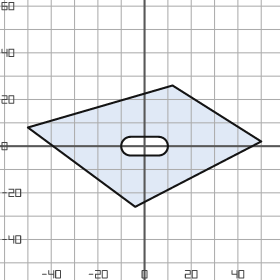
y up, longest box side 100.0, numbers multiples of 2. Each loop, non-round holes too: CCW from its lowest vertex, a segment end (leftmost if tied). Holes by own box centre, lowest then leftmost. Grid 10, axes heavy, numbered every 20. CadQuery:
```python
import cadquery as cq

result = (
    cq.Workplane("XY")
    .moveTo(-4.0, -26.0)
    .lineTo(50.0, 2.0)
    .lineTo(12.0, 26.0)
    .lineTo(-50.0, 8.0)
    .close()
    .moveTo(-6.0, -4.0)
    .lineTo(6.0, -4.0)
    .threePointArc((10.0, 0.0), (6.0, 4.0))
    .lineTo(-6.0, 4.0)
    .threePointArc((-10.0, 0.0), (-6.0, -4.0))
    .close()
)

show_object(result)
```